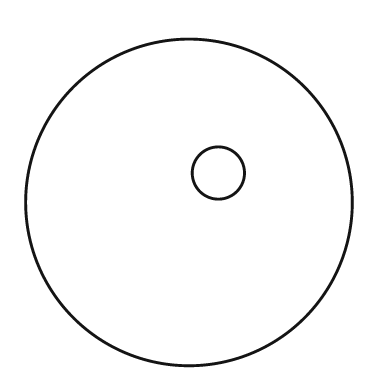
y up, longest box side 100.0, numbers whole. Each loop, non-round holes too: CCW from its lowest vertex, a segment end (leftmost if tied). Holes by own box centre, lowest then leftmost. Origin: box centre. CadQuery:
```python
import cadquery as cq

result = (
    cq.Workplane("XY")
    .moveTo(0.0, 0.0)
    .circle(50.0)
    .moveTo(9.0, 9.0)
    .circle(8.0)
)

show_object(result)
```